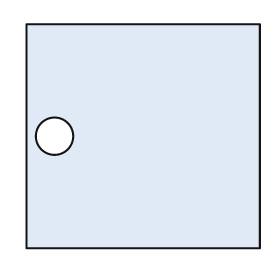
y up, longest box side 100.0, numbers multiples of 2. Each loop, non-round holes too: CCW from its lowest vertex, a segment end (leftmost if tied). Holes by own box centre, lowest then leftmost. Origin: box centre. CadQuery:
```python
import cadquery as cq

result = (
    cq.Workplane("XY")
    .moveTo(-50.0, -48.0)
    .lineTo(50.0, -48.0)
    .lineTo(50.0, 48.0)
    .lineTo(-50.0, 48.0)
    .close()
    .moveTo(-38.0, 0.0)
    .circle(8.0)
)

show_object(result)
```